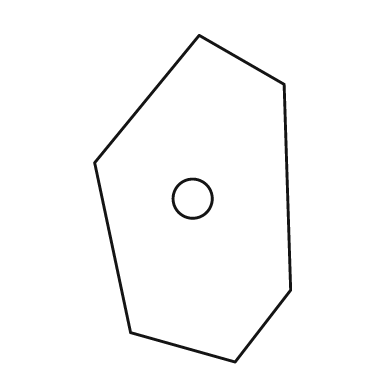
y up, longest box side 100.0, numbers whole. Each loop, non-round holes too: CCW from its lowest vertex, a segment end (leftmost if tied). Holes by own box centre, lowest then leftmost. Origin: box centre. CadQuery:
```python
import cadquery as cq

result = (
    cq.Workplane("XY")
    .moveTo(13.0, -50.0)
    .lineTo(30.0, -28.0)
    .lineTo(28.0, 35.0)
    .lineTo(2.0, 50.0)
    .lineTo(-30.0, 11.0)
    .lineTo(-19.0, -41.0)
    .close()
    .moveTo(0.0, 0.0)
    .circle(6.0)
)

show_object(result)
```